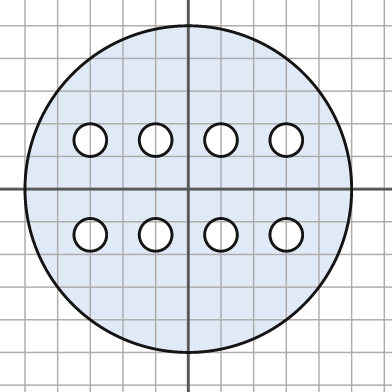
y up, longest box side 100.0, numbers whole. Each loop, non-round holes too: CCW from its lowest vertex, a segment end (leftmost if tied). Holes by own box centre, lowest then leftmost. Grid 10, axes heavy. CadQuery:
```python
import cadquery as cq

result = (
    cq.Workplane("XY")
    .moveTo(0.0, 0.0)
    .circle(50.0)
    .moveTo(-30.0, -14.0)
    .circle(5.0)
    .moveTo(-10.0, -14.0)
    .circle(5.0)
    .moveTo(10.0, -14.0)
    .circle(5.0)
    .moveTo(30.0, -14.0)
    .circle(5.0)
    .moveTo(-30.0, 15.0)
    .circle(5.0)
    .moveTo(-10.0, 15.0)
    .circle(5.0)
    .moveTo(10.0, 15.0)
    .circle(5.0)
    .moveTo(30.0, 15.0)
    .circle(5.0)
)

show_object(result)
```